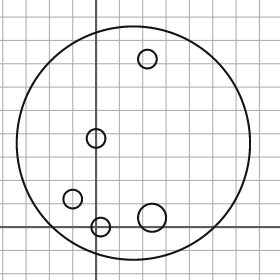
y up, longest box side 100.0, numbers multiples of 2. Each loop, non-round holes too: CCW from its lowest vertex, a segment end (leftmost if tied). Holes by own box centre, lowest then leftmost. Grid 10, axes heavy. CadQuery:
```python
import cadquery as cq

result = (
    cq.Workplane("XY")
    .moveTo(16.0, 36.0)
    .circle(50.0)
    .moveTo(2.0, 0.0)
    .circle(4.0)
    .moveTo(24.0, 4.0)
    .circle(6.0)
    .moveTo(-10.0, 12.0)
    .circle(4.0)
    .moveTo(0.0, 38.0)
    .circle(4.0)
    .moveTo(22.0, 72.0)
    .circle(4.0)
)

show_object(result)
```